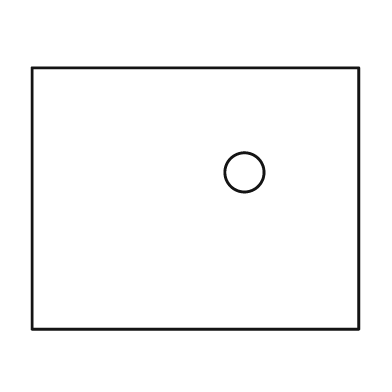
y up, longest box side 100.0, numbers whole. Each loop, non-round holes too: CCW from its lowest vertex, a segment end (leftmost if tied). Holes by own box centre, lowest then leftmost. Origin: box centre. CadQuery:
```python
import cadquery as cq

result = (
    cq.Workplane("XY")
    .moveTo(-50.0, -40.0)
    .lineTo(50.0, -40.0)
    .lineTo(50.0, 40.0)
    .lineTo(-50.0, 40.0)
    .close()
    .moveTo(15.0, 8.0)
    .circle(6.0)
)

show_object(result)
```